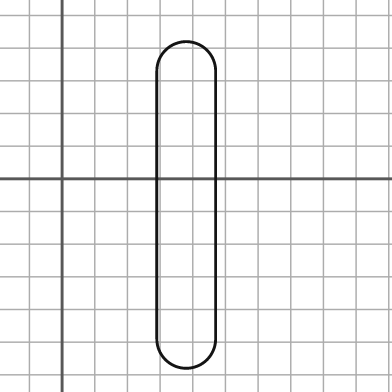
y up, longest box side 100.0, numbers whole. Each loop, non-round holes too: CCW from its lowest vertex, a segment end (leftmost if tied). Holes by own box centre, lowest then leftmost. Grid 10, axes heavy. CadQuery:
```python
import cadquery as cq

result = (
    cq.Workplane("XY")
    .moveTo(29.0, -49.0)
    .threePointArc((38.0, -58.0), (47.0, -49.0))
    .lineTo(47.0, 33.0)
    .threePointArc((38.0, 42.0), (29.0, 33.0))
    .close()
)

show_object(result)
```